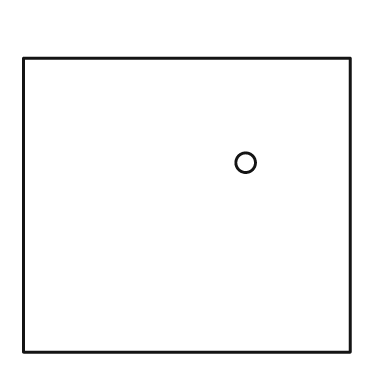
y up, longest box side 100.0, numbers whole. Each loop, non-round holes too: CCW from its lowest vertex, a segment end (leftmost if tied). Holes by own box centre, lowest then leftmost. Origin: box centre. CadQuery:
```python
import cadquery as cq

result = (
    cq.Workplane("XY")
    .moveTo(-50.0, -45.0)
    .lineTo(50.0, -45.0)
    .lineTo(50.0, 45.0)
    .lineTo(-50.0, 45.0)
    .close()
    .moveTo(18.0, 13.0)
    .circle(3.0)
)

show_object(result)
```